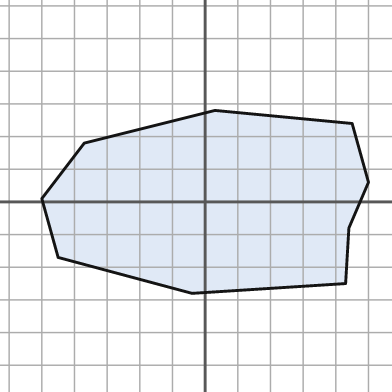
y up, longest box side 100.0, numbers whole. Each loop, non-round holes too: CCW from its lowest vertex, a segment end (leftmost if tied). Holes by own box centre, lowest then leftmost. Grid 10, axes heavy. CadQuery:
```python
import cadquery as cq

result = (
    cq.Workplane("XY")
    .moveTo(-4.0, -28.0)
    .lineTo(43.0, -25.0)
    .lineTo(44.0, -8.0)
    .lineTo(50.0, 6.0)
    .lineTo(45.0, 24.0)
    .lineTo(3.0, 28.0)
    .lineTo(-37.0, 18.0)
    .lineTo(-50.0, 1.0)
    .lineTo(-45.0, -17.0)
    .close()
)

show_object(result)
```